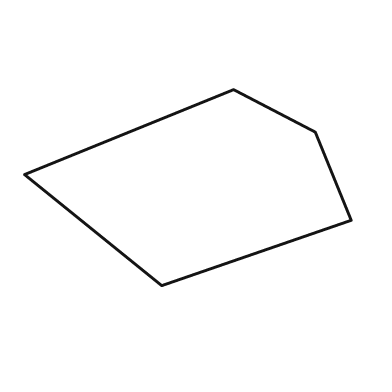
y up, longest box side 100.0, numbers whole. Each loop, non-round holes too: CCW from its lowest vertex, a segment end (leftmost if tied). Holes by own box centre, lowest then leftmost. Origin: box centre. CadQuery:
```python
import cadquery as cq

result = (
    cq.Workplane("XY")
    .moveTo(-8.0, -30.0)
    .lineTo(50.0, -10.0)
    .lineTo(39.0, 17.0)
    .lineTo(14.0, 30.0)
    .lineTo(-50.0, 4.0)
    .close()
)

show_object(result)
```